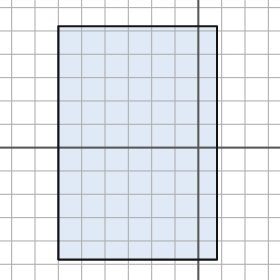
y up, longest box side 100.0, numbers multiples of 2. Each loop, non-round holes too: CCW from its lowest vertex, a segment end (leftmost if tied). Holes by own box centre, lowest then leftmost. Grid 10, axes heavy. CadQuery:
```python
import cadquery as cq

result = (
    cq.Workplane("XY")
    .moveTo(-60.0, -48.0)
    .lineTo(8.0, -48.0)
    .lineTo(8.0, 52.0)
    .lineTo(-60.0, 52.0)
    .close()
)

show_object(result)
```